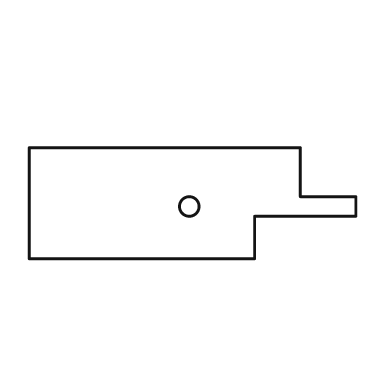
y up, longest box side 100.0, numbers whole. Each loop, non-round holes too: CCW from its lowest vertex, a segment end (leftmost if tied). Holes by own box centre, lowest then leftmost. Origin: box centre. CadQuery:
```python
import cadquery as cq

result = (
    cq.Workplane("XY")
    .moveTo(-50.0, -17.0)
    .lineTo(19.0, -17.0)
    .lineTo(19.0, -4.0)
    .lineTo(50.0, -4.0)
    .lineTo(50.0, 2.0)
    .lineTo(33.0, 2.0)
    .lineTo(33.0, 17.0)
    .lineTo(-50.0, 17.0)
    .close()
    .moveTo(-1.0, -1.0)
    .circle(3.0)
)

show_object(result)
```